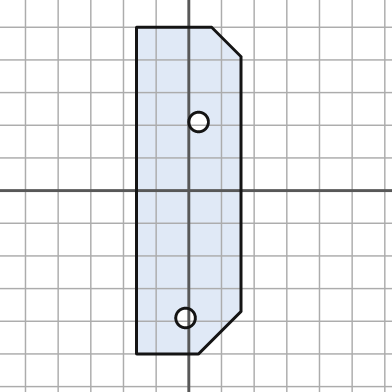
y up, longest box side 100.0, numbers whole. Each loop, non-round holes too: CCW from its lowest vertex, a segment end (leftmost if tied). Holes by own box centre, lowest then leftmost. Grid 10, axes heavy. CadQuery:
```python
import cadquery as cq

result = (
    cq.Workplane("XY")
    .moveTo(-16.0, -50.0)
    .lineTo(3.0, -50.0)
    .lineTo(16.0, -37.0)
    .lineTo(16.0, 41.0)
    .lineTo(7.0, 50.0)
    .lineTo(-16.0, 50.0)
    .close()
    .moveTo(-1.0, -39.0)
    .circle(3.0)
    .moveTo(3.0, 21.0)
    .circle(3.0)
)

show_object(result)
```